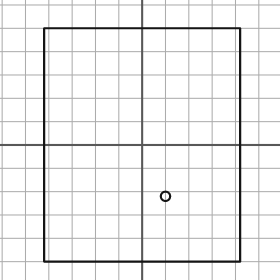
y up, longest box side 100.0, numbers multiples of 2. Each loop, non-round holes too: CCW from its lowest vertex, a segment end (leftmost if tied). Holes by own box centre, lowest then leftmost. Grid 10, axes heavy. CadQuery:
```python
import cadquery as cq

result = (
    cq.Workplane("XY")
    .moveTo(-42.0, -50.0)
    .lineTo(42.0, -50.0)
    .lineTo(42.0, 50.0)
    .lineTo(-42.0, 50.0)
    .close()
    .moveTo(10.0, -22.0)
    .circle(2.0)
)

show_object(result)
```